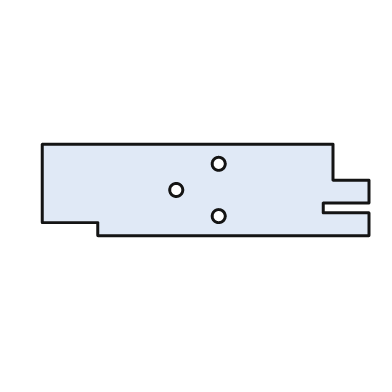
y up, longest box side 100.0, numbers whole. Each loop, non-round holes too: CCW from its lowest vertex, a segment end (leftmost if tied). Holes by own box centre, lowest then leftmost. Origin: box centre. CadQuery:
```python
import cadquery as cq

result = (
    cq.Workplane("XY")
    .moveTo(-33.0, -14.0)
    .lineTo(50.0, -14.0)
    .lineTo(50.0, -7.0)
    .lineTo(36.0, -7.0)
    .lineTo(36.0, -4.0)
    .lineTo(50.0, -4.0)
    .lineTo(50.0, 3.0)
    .lineTo(39.0, 3.0)
    .lineTo(39.0, 14.0)
    .lineTo(-50.0, 14.0)
    .lineTo(-50.0, -10.0)
    .lineTo(-33.0, -10.0)
    .close()
    .moveTo(4.0, -8.0)
    .circle(2.0)
    .moveTo(-9.0, 0.0)
    .circle(2.0)
    .moveTo(4.0, 8.0)
    .circle(2.0)
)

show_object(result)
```